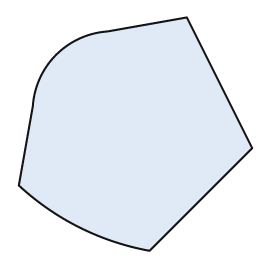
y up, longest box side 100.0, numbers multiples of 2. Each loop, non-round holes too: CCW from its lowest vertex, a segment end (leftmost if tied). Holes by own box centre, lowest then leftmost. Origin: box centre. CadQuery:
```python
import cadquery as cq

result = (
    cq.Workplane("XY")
    .moveTo(6.0, -50.0)
    .lineTo(50.0, -6.0)
    .lineTo(22.0, 50.0)
    .lineTo(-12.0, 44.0)
    .threePointArc((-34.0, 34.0), (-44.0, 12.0))
    .lineTo(-50.0, -22.0)
    .threePointArc((-24.0, -40.0), (6.0, -50.0))
    .close()
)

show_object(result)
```